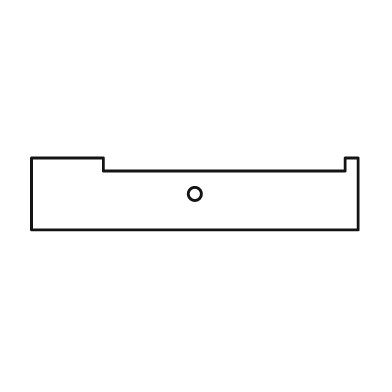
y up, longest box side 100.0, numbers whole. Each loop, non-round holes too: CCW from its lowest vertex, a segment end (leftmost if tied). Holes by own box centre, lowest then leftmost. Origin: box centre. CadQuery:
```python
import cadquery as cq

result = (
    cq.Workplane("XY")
    .moveTo(-50.0, -11.0)
    .lineTo(50.0, -11.0)
    .lineTo(50.0, 11.0)
    .lineTo(46.0, 11.0)
    .lineTo(46.0, 7.0)
    .lineTo(-28.0, 7.0)
    .lineTo(-28.0, 11.0)
    .lineTo(-50.0, 11.0)
    .close()
    .moveTo(0.0, 0.0)
    .circle(2.0)
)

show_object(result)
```